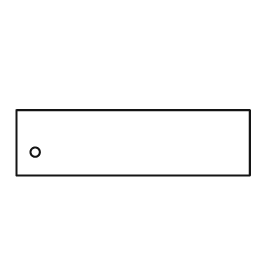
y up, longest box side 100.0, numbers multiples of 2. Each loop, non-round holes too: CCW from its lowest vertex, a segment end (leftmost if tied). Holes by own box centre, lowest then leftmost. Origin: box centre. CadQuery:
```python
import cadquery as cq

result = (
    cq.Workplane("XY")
    .moveTo(-50.0, -14.0)
    .lineTo(50.0, -14.0)
    .lineTo(50.0, 14.0)
    .lineTo(-50.0, 14.0)
    .close()
    .moveTo(-42.0, -4.0)
    .circle(2.0)
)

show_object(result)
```